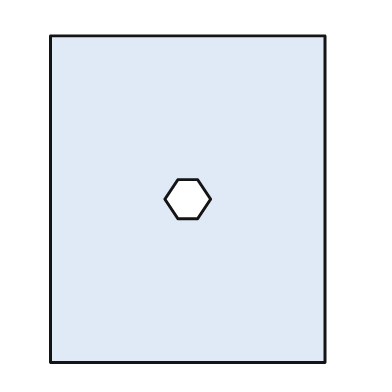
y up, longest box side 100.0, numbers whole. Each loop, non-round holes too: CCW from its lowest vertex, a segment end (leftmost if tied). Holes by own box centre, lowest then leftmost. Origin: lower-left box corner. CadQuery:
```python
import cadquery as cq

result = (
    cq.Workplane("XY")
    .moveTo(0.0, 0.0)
    .lineTo(84.0, 0.0)
    .lineTo(84.0, 100.0)
    .lineTo(0.0, 100.0)
    .close()
    .moveTo(39.0, 44.0)
    .lineTo(45.0, 44.0)
    .lineTo(49.0, 50.0)
    .lineTo(45.0, 56.0)
    .lineTo(39.0, 56.0)
    .lineTo(35.0, 50.0)
    .close()
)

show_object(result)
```